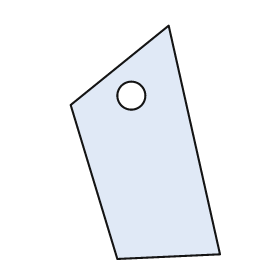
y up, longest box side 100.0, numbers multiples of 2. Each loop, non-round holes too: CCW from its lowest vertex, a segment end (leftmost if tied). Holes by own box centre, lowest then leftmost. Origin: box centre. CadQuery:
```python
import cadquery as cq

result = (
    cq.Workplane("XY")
    .moveTo(-12.0, -50.0)
    .lineTo(32.0, -48.0)
    .lineTo(10.0, 50.0)
    .lineTo(-32.0, 16.0)
    .close()
    .moveTo(-6.0, 20.0)
    .circle(6.0)
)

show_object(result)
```